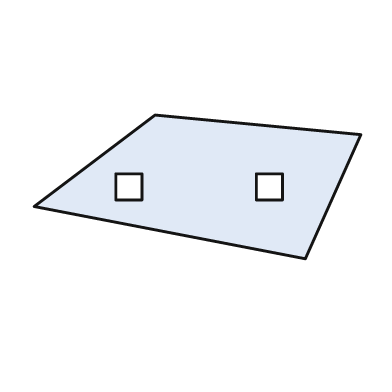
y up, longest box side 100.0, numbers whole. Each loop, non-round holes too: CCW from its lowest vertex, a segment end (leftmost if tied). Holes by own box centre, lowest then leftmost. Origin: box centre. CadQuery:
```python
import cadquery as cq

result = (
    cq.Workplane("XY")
    .moveTo(33.0, -22.0)
    .lineTo(50.0, 16.0)
    .lineTo(-13.0, 22.0)
    .lineTo(-50.0, -6.0)
    .close()
    .moveTo(-25.0, -4.0)
    .lineTo(-17.0, -4.0)
    .lineTo(-17.0, 4.0)
    .lineTo(-25.0, 4.0)
    .close()
    .moveTo(18.0, -4.0)
    .lineTo(26.0, -4.0)
    .lineTo(26.0, 4.0)
    .lineTo(18.0, 4.0)
    .close()
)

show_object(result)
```